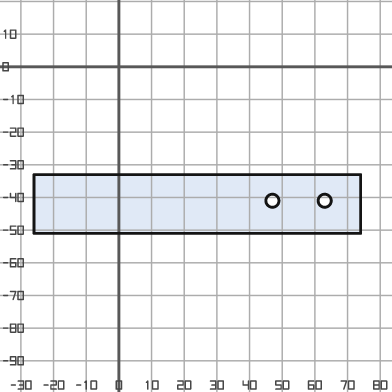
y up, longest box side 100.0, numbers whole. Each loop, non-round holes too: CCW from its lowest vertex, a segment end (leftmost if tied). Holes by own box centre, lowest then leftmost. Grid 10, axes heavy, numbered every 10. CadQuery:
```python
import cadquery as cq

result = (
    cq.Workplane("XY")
    .moveTo(-26.0, -51.0)
    .lineTo(74.0, -51.0)
    .lineTo(74.0, -33.0)
    .lineTo(-26.0, -33.0)
    .close()
    .moveTo(47.0, -41.0)
    .circle(2.0)
    .moveTo(63.0, -41.0)
    .circle(2.0)
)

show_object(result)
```